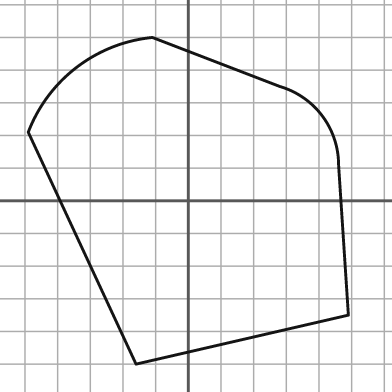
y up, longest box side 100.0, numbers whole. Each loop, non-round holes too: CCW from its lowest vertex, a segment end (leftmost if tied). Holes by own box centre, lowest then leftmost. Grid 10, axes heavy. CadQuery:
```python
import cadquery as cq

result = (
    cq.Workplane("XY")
    .moveTo(-16.0, -50.0)
    .lineTo(49.0, -35.0)
    .lineTo(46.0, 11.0)
    .threePointArc((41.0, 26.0), (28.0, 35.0))
    .lineTo(-11.0, 50.0)
    .threePointArc((-34.0, 41.0), (-49.0, 21.0))
    .close()
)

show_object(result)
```